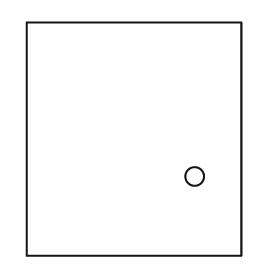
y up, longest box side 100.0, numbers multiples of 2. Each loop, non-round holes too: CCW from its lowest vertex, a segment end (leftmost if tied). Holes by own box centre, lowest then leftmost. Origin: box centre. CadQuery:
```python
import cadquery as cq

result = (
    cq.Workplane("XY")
    .moveTo(-46.0, -50.0)
    .lineTo(46.0, -50.0)
    .lineTo(46.0, 50.0)
    .lineTo(-46.0, 50.0)
    .close()
    .moveTo(26.0, -16.0)
    .circle(4.0)
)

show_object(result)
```